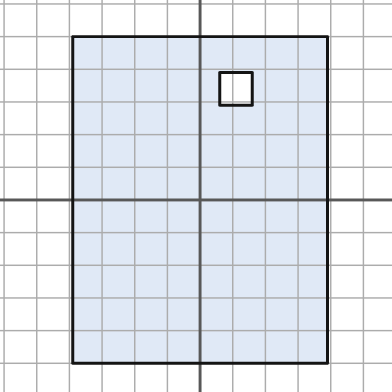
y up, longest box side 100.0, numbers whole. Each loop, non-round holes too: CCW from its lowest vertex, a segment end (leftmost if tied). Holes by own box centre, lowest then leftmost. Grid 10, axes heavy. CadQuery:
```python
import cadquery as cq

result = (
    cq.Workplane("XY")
    .moveTo(-39.0, -50.0)
    .lineTo(39.0, -50.0)
    .lineTo(39.0, 50.0)
    .lineTo(-39.0, 50.0)
    .close()
    .moveTo(6.0, 29.0)
    .lineTo(16.0, 29.0)
    .lineTo(16.0, 39.0)
    .lineTo(6.0, 39.0)
    .close()
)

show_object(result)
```